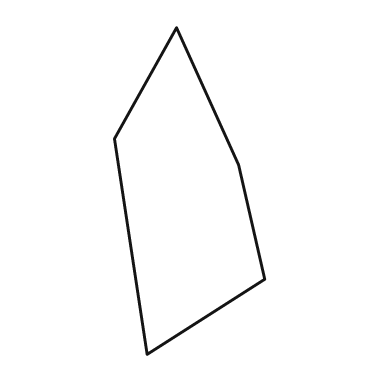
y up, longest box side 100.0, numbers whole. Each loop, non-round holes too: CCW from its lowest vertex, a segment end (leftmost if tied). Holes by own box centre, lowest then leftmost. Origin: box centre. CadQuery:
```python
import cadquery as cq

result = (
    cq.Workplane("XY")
    .moveTo(-13.0, -50.0)
    .lineTo(23.0, -27.0)
    .lineTo(15.0, 8.0)
    .lineTo(-4.0, 50.0)
    .lineTo(-23.0, 16.0)
    .close()
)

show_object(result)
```